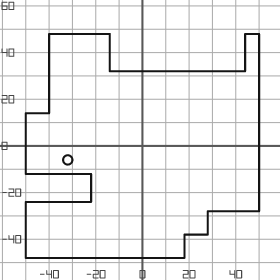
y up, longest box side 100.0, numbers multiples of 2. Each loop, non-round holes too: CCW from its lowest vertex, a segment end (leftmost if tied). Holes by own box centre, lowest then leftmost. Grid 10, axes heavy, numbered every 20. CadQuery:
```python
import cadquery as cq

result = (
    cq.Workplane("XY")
    .moveTo(-50.0, -48.0)
    .lineTo(18.0, -48.0)
    .lineTo(18.0, -38.0)
    .lineTo(28.0, -38.0)
    .lineTo(28.0, -28.0)
    .lineTo(50.0, -28.0)
    .lineTo(50.0, 48.0)
    .lineTo(44.0, 48.0)
    .lineTo(44.0, 32.0)
    .lineTo(-14.0, 32.0)
    .lineTo(-14.0, 48.0)
    .lineTo(-40.0, 48.0)
    .lineTo(-40.0, 14.0)
    .lineTo(-50.0, 14.0)
    .lineTo(-50.0, -12.0)
    .lineTo(-22.0, -12.0)
    .lineTo(-22.0, -24.0)
    .lineTo(-50.0, -24.0)
    .close()
    .moveTo(-32.0, -6.0)
    .circle(2.0)
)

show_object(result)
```